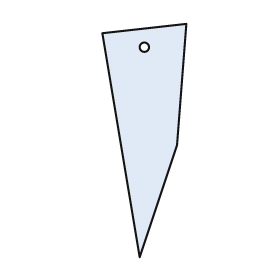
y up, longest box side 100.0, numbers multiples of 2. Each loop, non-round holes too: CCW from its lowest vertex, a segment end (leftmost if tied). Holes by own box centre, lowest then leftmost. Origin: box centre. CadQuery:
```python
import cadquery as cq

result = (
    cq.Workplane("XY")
    .moveTo(-2.0, -50.0)
    .lineTo(14.0, -2.0)
    .lineTo(18.0, 50.0)
    .lineTo(-18.0, 46.0)
    .close()
    .moveTo(0.0, 40.0)
    .circle(2.0)
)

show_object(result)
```